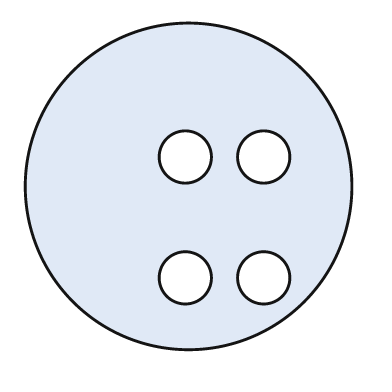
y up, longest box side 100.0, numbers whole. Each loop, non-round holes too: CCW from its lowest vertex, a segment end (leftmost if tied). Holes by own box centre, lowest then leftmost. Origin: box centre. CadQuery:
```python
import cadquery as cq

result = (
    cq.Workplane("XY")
    .moveTo(0.0, 0.0)
    .circle(50.0)
    .moveTo(-1.0, -28.0)
    .circle(8.0)
    .moveTo(23.0, -28.0)
    .circle(8.0)
    .moveTo(-1.0, 9.0)
    .circle(8.0)
    .moveTo(23.0, 9.0)
    .circle(8.0)
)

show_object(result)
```